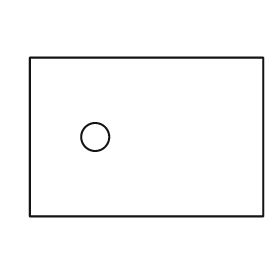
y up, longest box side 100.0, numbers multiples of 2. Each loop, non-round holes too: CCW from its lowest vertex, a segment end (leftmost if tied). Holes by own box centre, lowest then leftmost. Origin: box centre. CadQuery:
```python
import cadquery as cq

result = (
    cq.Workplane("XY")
    .moveTo(-50.0, -34.0)
    .lineTo(50.0, -34.0)
    .lineTo(50.0, 34.0)
    .lineTo(-50.0, 34.0)
    .close()
    .moveTo(-22.0, 0.0)
    .circle(6.0)
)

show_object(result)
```